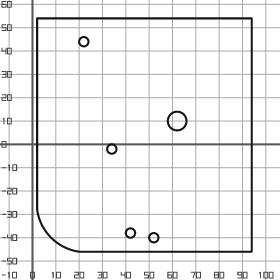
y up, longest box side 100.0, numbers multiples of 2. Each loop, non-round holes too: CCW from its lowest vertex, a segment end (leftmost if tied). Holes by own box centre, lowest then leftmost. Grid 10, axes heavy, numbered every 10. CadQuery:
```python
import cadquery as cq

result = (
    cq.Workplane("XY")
    .moveTo(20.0, -46.0)
    .lineTo(94.0, -46.0)
    .lineTo(94.0, 54.0)
    .lineTo(2.0, 54.0)
    .lineTo(2.0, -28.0)
    .threePointArc((8.0, -40.0), (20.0, -46.0))
    .close()
    .moveTo(52.0, -40.0)
    .circle(2.0)
    .moveTo(42.0, -38.0)
    .circle(2.0)
    .moveTo(34.0, -2.0)
    .circle(2.0)
    .moveTo(62.0, 10.0)
    .circle(4.0)
    .moveTo(22.0, 44.0)
    .circle(2.0)
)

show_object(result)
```